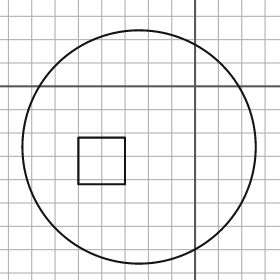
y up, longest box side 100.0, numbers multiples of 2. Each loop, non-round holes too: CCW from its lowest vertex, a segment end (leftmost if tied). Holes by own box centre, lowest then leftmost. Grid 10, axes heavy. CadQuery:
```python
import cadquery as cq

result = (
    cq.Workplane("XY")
    .moveTo(-24.0, -26.0)
    .circle(50.0)
    .moveTo(-50.0, -42.0)
    .lineTo(-30.0, -42.0)
    .lineTo(-30.0, -22.0)
    .lineTo(-50.0, -22.0)
    .close()
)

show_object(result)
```